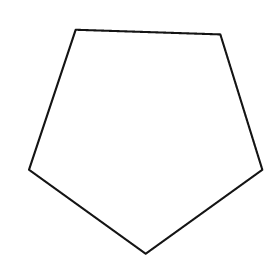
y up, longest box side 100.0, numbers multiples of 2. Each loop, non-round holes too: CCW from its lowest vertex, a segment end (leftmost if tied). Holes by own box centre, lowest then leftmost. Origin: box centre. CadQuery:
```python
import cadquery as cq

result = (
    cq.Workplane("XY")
    .moveTo(0.0, -48.0)
    .lineTo(50.0, -12.0)
    .lineTo(32.0, 46.0)
    .lineTo(-30.0, 48.0)
    .lineTo(-50.0, -12.0)
    .close()
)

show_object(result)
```